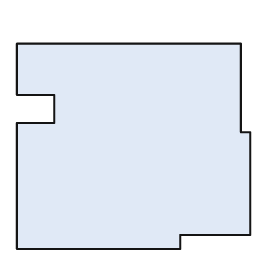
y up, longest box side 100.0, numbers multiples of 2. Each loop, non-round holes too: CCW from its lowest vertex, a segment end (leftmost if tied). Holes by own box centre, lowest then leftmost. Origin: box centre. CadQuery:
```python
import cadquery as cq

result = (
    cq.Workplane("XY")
    .moveTo(-50.0, -44.0)
    .lineTo(20.0, -44.0)
    .lineTo(20.0, -38.0)
    .lineTo(50.0, -38.0)
    .lineTo(50.0, 6.0)
    .lineTo(46.0, 6.0)
    .lineTo(46.0, 44.0)
    .lineTo(-50.0, 44.0)
    .lineTo(-50.0, 22.0)
    .lineTo(-34.0, 22.0)
    .lineTo(-34.0, 10.0)
    .lineTo(-50.0, 10.0)
    .close()
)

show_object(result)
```